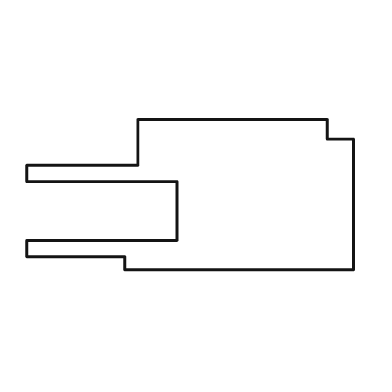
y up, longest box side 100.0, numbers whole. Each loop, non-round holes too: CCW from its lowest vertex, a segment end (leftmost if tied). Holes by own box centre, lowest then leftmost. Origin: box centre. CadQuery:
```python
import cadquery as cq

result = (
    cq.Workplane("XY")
    .moveTo(-20.0, -23.0)
    .lineTo(50.0, -23.0)
    .lineTo(50.0, 17.0)
    .lineTo(42.0, 17.0)
    .lineTo(42.0, 23.0)
    .lineTo(-16.0, 23.0)
    .lineTo(-16.0, 9.0)
    .lineTo(-50.0, 9.0)
    .lineTo(-50.0, 4.0)
    .lineTo(-4.0, 4.0)
    .lineTo(-4.0, -14.0)
    .lineTo(-50.0, -14.0)
    .lineTo(-50.0, -19.0)
    .lineTo(-20.0, -19.0)
    .close()
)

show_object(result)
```